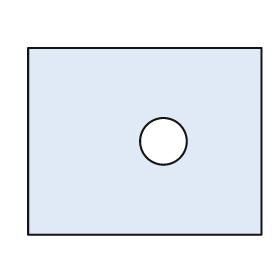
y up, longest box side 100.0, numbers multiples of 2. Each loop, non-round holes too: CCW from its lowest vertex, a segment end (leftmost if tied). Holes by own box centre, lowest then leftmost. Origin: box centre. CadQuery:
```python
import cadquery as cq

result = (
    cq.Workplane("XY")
    .moveTo(-50.0, -40.0)
    .lineTo(50.0, -40.0)
    .lineTo(50.0, 40.0)
    .lineTo(-50.0, 40.0)
    .close()
    .moveTo(8.0, 0.0)
    .circle(10.0)
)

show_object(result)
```